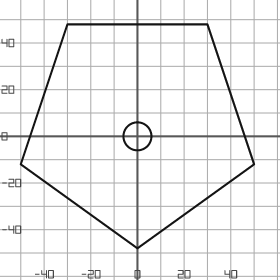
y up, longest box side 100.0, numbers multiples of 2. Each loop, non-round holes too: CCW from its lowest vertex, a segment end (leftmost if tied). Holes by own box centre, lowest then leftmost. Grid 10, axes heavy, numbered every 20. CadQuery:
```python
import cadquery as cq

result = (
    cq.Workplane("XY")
    .moveTo(0.0, -48.0)
    .lineTo(50.0, -12.0)
    .lineTo(30.0, 48.0)
    .lineTo(-30.0, 48.0)
    .lineTo(-50.0, -12.0)
    .close()
    .moveTo(0.0, 0.0)
    .circle(6.0)
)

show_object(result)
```